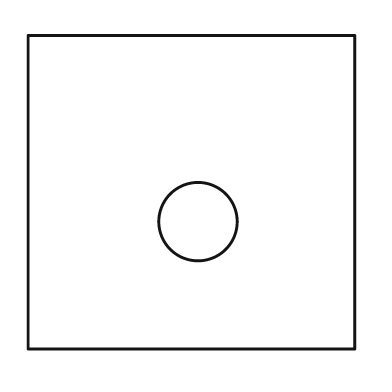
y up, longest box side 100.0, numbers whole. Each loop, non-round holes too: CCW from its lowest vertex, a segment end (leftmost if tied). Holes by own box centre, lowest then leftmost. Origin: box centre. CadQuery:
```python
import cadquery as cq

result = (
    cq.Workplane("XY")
    .moveTo(-50.0, -48.0)
    .lineTo(50.0, -48.0)
    .lineTo(50.0, 48.0)
    .lineTo(-50.0, 48.0)
    .close()
    .moveTo(2.0, -9.0)
    .circle(12.0)
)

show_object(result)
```